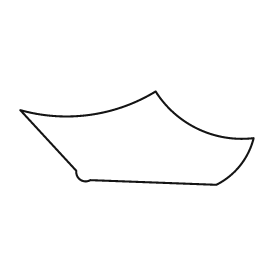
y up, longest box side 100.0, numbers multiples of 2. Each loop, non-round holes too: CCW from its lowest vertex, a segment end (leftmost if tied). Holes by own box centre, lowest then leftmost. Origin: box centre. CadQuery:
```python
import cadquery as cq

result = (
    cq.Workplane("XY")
    .moveTo(34.0, -20.0)
    .threePointArc((44.0, -12.0), (50.0, 0.0))
    .threePointArc((26.0, 4.0), (8.0, 20.0))
    .threePointArc((-20.0, 10.0), (-50.0, 12.0))
    .lineTo(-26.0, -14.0)
    .threePointArc((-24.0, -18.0), (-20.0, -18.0))
    .close()
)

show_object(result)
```